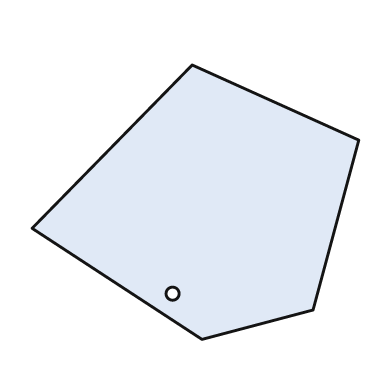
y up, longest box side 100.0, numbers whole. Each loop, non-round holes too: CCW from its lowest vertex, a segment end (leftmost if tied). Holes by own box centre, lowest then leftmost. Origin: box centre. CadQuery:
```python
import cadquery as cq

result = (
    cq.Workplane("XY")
    .moveTo(2.0, -42.0)
    .lineTo(36.0, -33.0)
    .lineTo(50.0, 19.0)
    .lineTo(-1.0, 42.0)
    .lineTo(-50.0, -8.0)
    .close()
    .moveTo(-7.0, -28.0)
    .circle(2.0)
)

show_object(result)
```